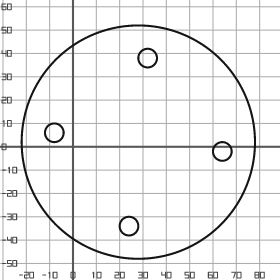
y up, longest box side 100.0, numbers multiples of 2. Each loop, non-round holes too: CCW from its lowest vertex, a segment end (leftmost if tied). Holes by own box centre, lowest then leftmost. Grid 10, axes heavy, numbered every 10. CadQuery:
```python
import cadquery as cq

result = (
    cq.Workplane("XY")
    .moveTo(28.0, 2.0)
    .circle(50.0)
    .moveTo(24.0, -34.0)
    .circle(4.0)
    .moveTo(64.0, -2.0)
    .circle(4.0)
    .moveTo(-8.0, 6.0)
    .circle(4.0)
    .moveTo(32.0, 38.0)
    .circle(4.0)
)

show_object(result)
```